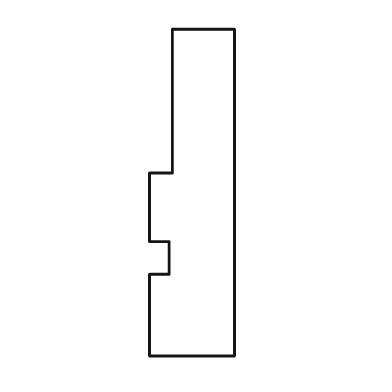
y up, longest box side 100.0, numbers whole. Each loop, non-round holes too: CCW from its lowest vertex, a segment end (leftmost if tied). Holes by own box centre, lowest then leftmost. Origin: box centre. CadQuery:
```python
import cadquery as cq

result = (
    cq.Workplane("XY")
    .moveTo(-13.0, -50.0)
    .lineTo(13.0, -50.0)
    .lineTo(13.0, 50.0)
    .lineTo(-6.0, 50.0)
    .lineTo(-6.0, 6.0)
    .lineTo(-13.0, 6.0)
    .lineTo(-13.0, -15.0)
    .lineTo(-7.0, -15.0)
    .lineTo(-7.0, -25.0)
    .lineTo(-13.0, -25.0)
    .close()
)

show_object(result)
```